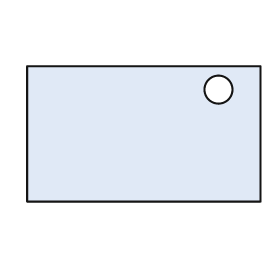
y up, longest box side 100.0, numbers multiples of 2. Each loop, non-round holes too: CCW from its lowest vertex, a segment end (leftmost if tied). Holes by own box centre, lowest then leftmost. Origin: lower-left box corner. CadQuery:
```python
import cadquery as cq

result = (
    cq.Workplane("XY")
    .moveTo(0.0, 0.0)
    .lineTo(100.0, 0.0)
    .lineTo(100.0, 58.0)
    .lineTo(0.0, 58.0)
    .close()
    .moveTo(82.0, 48.0)
    .circle(6.0)
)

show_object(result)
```